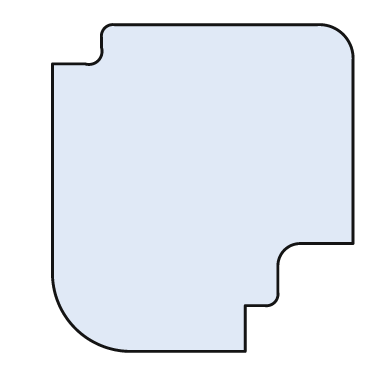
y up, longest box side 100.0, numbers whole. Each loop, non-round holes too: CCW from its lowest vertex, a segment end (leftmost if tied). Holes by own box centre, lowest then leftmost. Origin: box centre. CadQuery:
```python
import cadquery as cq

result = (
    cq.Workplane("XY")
    .moveTo(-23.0, -50.0)
    .lineTo(13.0, -50.0)
    .lineTo(13.0, -36.0)
    .lineTo(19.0, -36.0)
    .threePointArc((22.0, -35.0), (23.0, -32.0))
    .lineTo(23.0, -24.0)
    .threePointArc((25.0, -19.0), (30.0, -17.0))
    .lineTo(46.0, -17.0)
    .lineTo(46.0, 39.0)
    .threePointArc((43.0, 47.0), (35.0, 50.0))
    .lineTo(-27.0, 50.0)
    .threePointArc((-30.0, 49.0), (-31.0, 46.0))
    .lineTo(-31.0, 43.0)
    .threePointArc((-32.0, 39.0), (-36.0, 38.0))
    .lineTo(-46.0, 38.0)
    .lineTo(-46.0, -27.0)
    .threePointArc((-39.0, -43.0), (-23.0, -50.0))
    .close()
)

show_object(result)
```